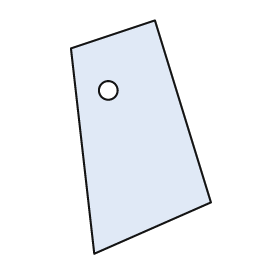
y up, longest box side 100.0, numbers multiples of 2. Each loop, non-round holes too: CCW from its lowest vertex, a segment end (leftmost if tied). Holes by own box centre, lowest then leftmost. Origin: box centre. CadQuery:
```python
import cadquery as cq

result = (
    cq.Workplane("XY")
    .moveTo(-20.0, -50.0)
    .lineTo(30.0, -28.0)
    .lineTo(6.0, 50.0)
    .lineTo(-30.0, 38.0)
    .close()
    .moveTo(-14.0, 20.0)
    .circle(4.0)
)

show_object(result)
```